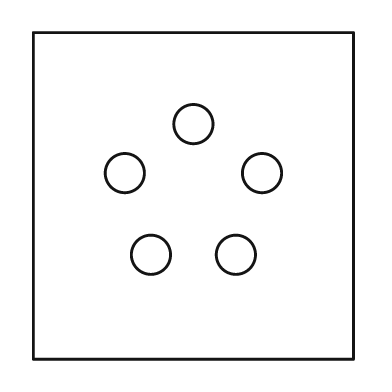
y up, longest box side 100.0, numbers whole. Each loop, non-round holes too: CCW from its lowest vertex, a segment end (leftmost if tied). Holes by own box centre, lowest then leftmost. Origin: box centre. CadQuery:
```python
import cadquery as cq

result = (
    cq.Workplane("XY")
    .moveTo(-49.0, -50.0)
    .lineTo(49.0, -50.0)
    .lineTo(49.0, 50.0)
    .lineTo(-49.0, 50.0)
    .close()
    .moveTo(-13.0, -18.0)
    .circle(6.0)
    .moveTo(13.0, -18.0)
    .circle(6.0)
    .moveTo(-21.0, 7.0)
    .circle(6.0)
    .moveTo(21.0, 7.0)
    .circle(6.0)
    .moveTo(0.0, 22.0)
    .circle(6.0)
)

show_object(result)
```